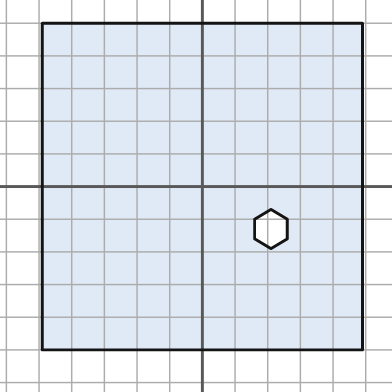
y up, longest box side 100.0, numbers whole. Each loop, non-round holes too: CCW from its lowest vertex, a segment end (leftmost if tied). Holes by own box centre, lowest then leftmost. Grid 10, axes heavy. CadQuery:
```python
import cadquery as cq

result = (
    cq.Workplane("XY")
    .moveTo(-49.0, -50.0)
    .lineTo(49.0, -50.0)
    .lineTo(49.0, 50.0)
    .lineTo(-49.0, 50.0)
    .close()
    .moveTo(21.0, -19.0)
    .lineTo(26.0, -16.0)
    .lineTo(26.0, -10.0)
    .lineTo(21.0, -7.0)
    .lineTo(16.0, -10.0)
    .lineTo(16.0, -16.0)
    .close()
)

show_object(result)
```